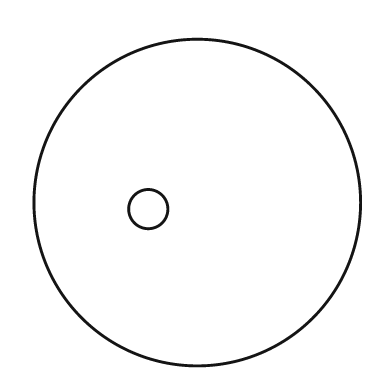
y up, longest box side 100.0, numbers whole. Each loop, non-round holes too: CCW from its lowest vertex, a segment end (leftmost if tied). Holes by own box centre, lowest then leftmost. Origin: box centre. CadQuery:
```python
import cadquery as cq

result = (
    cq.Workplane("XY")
    .moveTo(0.0, 0.0)
    .circle(50.0)
    .moveTo(-15.0, -2.0)
    .circle(6.0)
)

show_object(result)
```